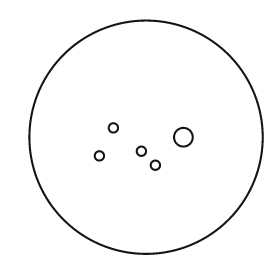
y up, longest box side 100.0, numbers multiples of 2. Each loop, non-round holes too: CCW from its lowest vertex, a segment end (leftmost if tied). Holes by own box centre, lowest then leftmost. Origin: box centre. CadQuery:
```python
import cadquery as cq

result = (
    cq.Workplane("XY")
    .moveTo(0.0, 0.0)
    .circle(50.0)
    .moveTo(4.0, -12.0)
    .circle(2.0)
    .moveTo(-20.0, -8.0)
    .circle(2.0)
    .moveTo(-2.0, -6.0)
    .circle(2.0)
    .moveTo(16.0, 0.0)
    .circle(4.0)
    .moveTo(-14.0, 4.0)
    .circle(2.0)
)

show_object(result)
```